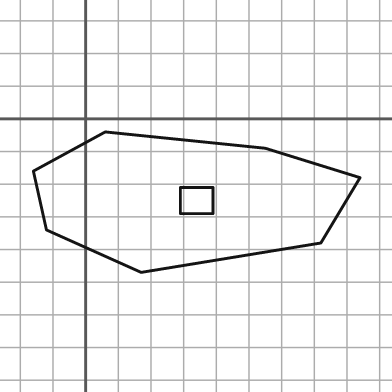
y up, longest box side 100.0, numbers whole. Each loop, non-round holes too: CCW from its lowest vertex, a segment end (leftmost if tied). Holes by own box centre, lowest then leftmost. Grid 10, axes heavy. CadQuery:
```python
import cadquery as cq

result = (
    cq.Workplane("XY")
    .moveTo(17.0, -47.0)
    .lineTo(72.0, -38.0)
    .lineTo(84.0, -18.0)
    .lineTo(55.0, -9.0)
    .lineTo(6.0, -4.0)
    .lineTo(-16.0, -16.0)
    .lineTo(-12.0, -34.0)
    .close()
    .moveTo(29.0, -29.0)
    .lineTo(39.0, -29.0)
    .lineTo(39.0, -21.0)
    .lineTo(29.0, -21.0)
    .close()
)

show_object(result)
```